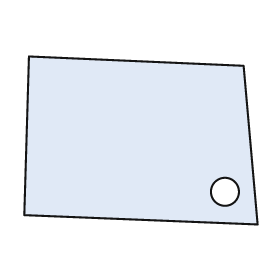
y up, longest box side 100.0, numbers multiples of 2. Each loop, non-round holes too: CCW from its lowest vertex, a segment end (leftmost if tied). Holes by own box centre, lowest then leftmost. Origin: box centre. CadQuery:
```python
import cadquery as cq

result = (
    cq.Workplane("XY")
    .moveTo(50.0, -36.0)
    .lineTo(44.0, 32.0)
    .lineTo(-48.0, 36.0)
    .lineTo(-50.0, -32.0)
    .close()
    .moveTo(36.0, -22.0)
    .circle(6.0)
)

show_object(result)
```